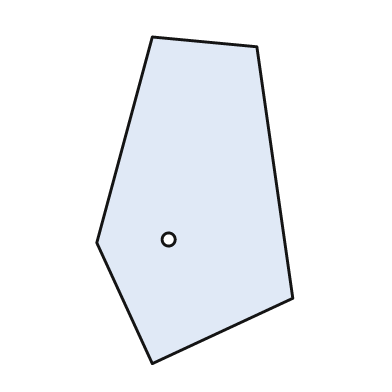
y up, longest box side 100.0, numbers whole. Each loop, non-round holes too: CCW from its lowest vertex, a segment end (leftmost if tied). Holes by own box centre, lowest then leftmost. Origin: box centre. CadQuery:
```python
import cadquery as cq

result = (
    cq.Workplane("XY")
    .moveTo(-13.0, -50.0)
    .lineTo(30.0, -30.0)
    .lineTo(19.0, 47.0)
    .lineTo(-13.0, 50.0)
    .lineTo(-30.0, -13.0)
    .close()
    .moveTo(-8.0, -12.0)
    .circle(2.0)
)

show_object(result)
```